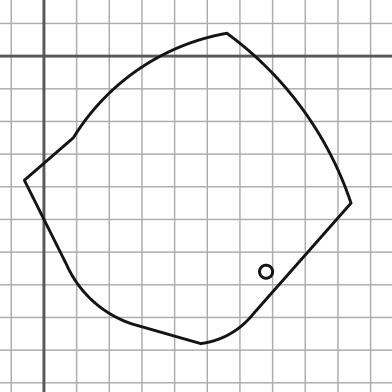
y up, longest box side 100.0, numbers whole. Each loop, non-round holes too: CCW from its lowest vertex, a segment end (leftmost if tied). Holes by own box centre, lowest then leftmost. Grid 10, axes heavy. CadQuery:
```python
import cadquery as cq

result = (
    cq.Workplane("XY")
    .moveTo(48.0, -88.0)
    .threePointArc((57.0, -85.0), (64.0, -79.0))
    .lineTo(94.0, -45.0)
    .threePointArc((79.0, -16.0), (56.0, 7.0))
    .threePointArc((29.0, -4.0), (9.0, -25.0))
    .lineTo(-6.0, -38.0)
    .lineTo(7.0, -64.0)
    .threePointArc((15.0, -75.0), (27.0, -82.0))
    .close()
    .moveTo(68.0, -66.0)
    .circle(2.0)
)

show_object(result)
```